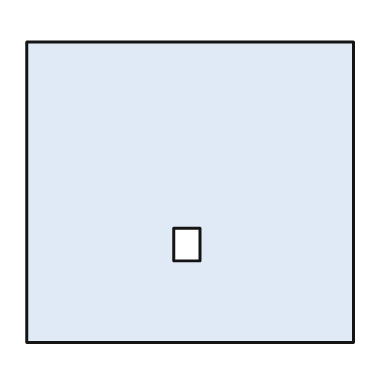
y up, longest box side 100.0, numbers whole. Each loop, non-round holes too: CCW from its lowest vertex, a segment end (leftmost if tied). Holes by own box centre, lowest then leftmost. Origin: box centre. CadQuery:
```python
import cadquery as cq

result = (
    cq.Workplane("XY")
    .moveTo(-50.0, -46.0)
    .lineTo(50.0, -46.0)
    .lineTo(50.0, 46.0)
    .lineTo(-50.0, 46.0)
    .close()
    .moveTo(-5.0, -21.0)
    .lineTo(3.0, -21.0)
    .lineTo(3.0, -11.0)
    .lineTo(-5.0, -11.0)
    .close()
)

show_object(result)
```